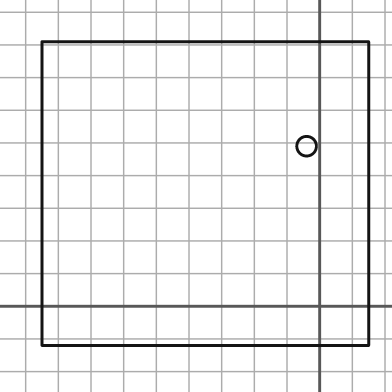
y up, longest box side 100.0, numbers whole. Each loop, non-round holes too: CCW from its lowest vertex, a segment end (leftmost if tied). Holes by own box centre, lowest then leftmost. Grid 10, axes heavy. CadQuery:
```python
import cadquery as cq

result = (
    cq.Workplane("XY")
    .moveTo(-85.0, -12.0)
    .lineTo(15.0, -12.0)
    .lineTo(15.0, 81.0)
    .lineTo(-85.0, 81.0)
    .close()
    .moveTo(-4.0, 49.0)
    .circle(3.0)
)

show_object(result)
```